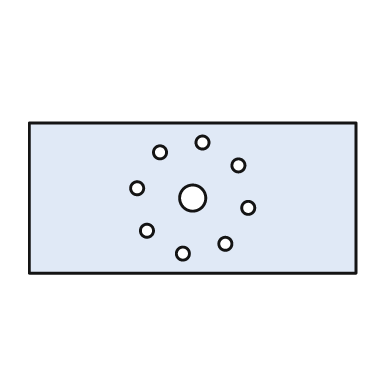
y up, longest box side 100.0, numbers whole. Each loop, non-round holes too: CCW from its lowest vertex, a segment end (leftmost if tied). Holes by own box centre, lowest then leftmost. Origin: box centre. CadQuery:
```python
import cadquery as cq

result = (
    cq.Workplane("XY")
    .moveTo(-50.0, -23.0)
    .lineTo(50.0, -23.0)
    .lineTo(50.0, 23.0)
    .lineTo(-50.0, 23.0)
    .close()
    .moveTo(-3.0, -17.0)
    .circle(2.0)
    .moveTo(10.0, -14.0)
    .circle(2.0)
    .moveTo(-14.0, -10.0)
    .circle(2.0)
    .moveTo(17.0, -3.0)
    .circle(2.0)
    .moveTo(0.0, 0.0)
    .circle(4.0)
    .moveTo(-17.0, 3.0)
    .circle(2.0)
    .moveTo(14.0, 10.0)
    .circle(2.0)
    .moveTo(-10.0, 14.0)
    .circle(2.0)
    .moveTo(3.0, 17.0)
    .circle(2.0)
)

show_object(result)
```